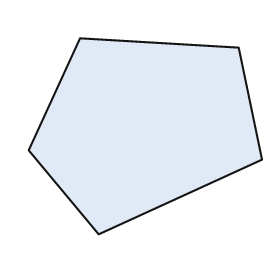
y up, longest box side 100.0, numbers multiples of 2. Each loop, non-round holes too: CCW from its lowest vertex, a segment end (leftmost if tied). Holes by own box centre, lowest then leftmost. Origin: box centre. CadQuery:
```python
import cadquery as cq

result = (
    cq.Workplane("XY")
    .moveTo(-20.0, -42.0)
    .lineTo(50.0, -10.0)
    .lineTo(40.0, 38.0)
    .lineTo(-28.0, 42.0)
    .lineTo(-50.0, -6.0)
    .close()
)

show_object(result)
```